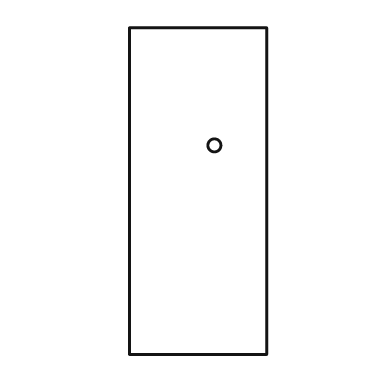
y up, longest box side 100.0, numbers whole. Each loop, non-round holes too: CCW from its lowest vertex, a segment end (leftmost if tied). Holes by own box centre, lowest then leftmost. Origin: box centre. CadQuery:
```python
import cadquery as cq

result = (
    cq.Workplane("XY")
    .moveTo(-21.0, -50.0)
    .lineTo(21.0, -50.0)
    .lineTo(21.0, 50.0)
    .lineTo(-21.0, 50.0)
    .close()
    .moveTo(5.0, 14.0)
    .circle(2.0)
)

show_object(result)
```